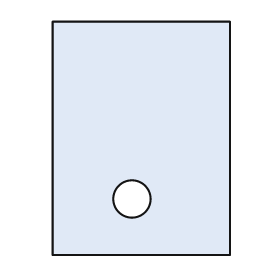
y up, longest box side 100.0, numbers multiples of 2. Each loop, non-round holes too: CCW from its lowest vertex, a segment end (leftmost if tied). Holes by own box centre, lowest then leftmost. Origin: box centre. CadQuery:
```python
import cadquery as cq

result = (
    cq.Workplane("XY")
    .moveTo(-38.0, -50.0)
    .lineTo(38.0, -50.0)
    .lineTo(38.0, 50.0)
    .lineTo(-38.0, 50.0)
    .close()
    .moveTo(-4.0, -26.0)
    .circle(8.0)
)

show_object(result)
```